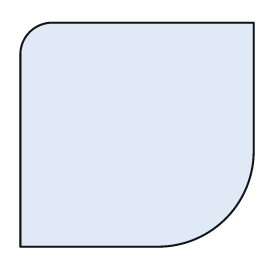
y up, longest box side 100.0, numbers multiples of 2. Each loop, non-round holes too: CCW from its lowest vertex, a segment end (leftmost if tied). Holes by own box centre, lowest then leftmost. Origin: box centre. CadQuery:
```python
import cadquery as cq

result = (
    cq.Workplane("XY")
    .moveTo(-50.0, -48.0)
    .lineTo(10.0, -48.0)
    .threePointArc((38.0, -36.0), (50.0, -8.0))
    .lineTo(50.0, 48.0)
    .lineTo(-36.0, 48.0)
    .threePointArc((-46.0, 44.0), (-50.0, 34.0))
    .close()
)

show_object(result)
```